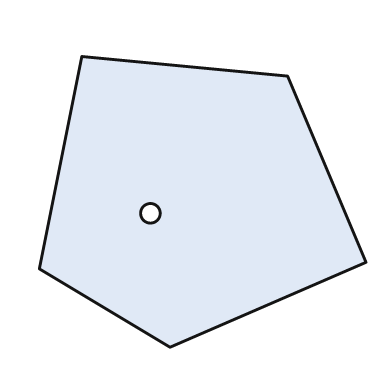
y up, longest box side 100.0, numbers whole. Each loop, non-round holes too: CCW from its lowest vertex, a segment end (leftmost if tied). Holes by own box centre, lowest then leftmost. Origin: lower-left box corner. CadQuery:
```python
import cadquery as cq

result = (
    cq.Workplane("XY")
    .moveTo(40.0, 0.0)
    .lineTo(100.0, 26.0)
    .lineTo(76.0, 83.0)
    .lineTo(13.0, 89.0)
    .lineTo(0.0, 24.0)
    .close()
    .moveTo(34.0, 41.0)
    .circle(3.0)
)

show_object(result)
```